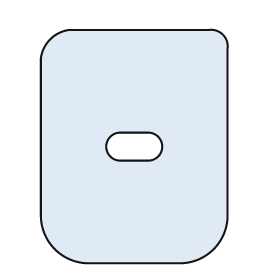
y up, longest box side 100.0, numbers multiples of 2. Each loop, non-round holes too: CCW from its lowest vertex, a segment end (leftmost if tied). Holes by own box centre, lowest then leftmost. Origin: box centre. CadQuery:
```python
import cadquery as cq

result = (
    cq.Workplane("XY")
    .moveTo(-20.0, -50.0)
    .lineTo(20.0, -50.0)
    .threePointArc((34.0, -44.0), (40.0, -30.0))
    .lineTo(40.0, 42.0)
    .threePointArc((38.0, 48.0), (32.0, 50.0))
    .lineTo(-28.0, 50.0)
    .threePointArc((-36.0, 46.0), (-40.0, 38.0))
    .lineTo(-40.0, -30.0)
    .threePointArc((-34.0, -44.0), (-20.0, -50.0))
    .close()
    .moveTo(-6.0, -6.0)
    .lineTo(6.0, -6.0)
    .threePointArc((12.0, 0.0), (6.0, 6.0))
    .lineTo(-6.0, 6.0)
    .threePointArc((-12.0, 0.0), (-6.0, -6.0))
    .close()
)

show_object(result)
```